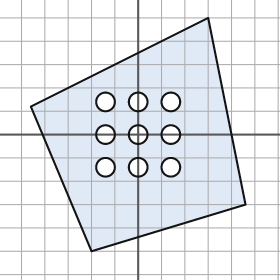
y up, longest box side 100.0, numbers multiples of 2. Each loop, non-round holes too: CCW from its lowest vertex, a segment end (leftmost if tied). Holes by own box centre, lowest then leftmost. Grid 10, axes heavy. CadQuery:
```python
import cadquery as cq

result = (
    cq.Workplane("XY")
    .moveTo(-20.0, -50.0)
    .lineTo(46.0, -30.0)
    .lineTo(30.0, 50.0)
    .lineTo(-46.0, 12.0)
    .close()
    .moveTo(-14.0, -14.0)
    .circle(4.0)
    .moveTo(0.0, -14.0)
    .circle(4.0)
    .moveTo(14.0, -14.0)
    .circle(4.0)
    .moveTo(-14.0, 0.0)
    .circle(4.0)
    .moveTo(0.0, 0.0)
    .circle(4.0)
    .moveTo(14.0, 0.0)
    .circle(4.0)
    .moveTo(-14.0, 14.0)
    .circle(4.0)
    .moveTo(0.0, 14.0)
    .circle(4.0)
    .moveTo(14.0, 14.0)
    .circle(4.0)
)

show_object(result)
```